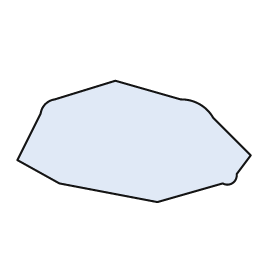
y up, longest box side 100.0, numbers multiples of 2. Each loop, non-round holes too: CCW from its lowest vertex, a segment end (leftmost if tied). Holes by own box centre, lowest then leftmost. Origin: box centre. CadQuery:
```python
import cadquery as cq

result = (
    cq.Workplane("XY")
    .moveTo(10.0, -26.0)
    .lineTo(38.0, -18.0)
    .threePointArc((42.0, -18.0), (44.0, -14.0))
    .lineTo(50.0, -6.0)
    .lineTo(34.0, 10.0)
    .threePointArc((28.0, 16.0), (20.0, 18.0))
    .lineTo(-8.0, 26.0)
    .lineTo(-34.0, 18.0)
    .threePointArc((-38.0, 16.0), (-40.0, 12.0))
    .lineTo(-50.0, -8.0)
    .lineTo(-32.0, -18.0)
    .close()
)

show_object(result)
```